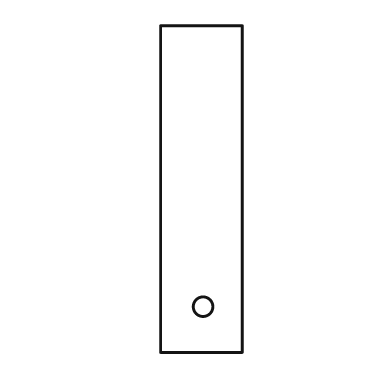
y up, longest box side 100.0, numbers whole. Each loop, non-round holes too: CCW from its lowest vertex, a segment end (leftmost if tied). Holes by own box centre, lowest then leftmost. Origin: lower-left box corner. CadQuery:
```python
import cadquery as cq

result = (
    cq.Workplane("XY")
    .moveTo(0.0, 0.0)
    .lineTo(25.0, 0.0)
    .lineTo(25.0, 100.0)
    .lineTo(0.0, 100.0)
    .close()
    .moveTo(13.0, 14.0)
    .circle(3.0)
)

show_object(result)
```